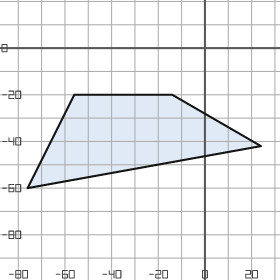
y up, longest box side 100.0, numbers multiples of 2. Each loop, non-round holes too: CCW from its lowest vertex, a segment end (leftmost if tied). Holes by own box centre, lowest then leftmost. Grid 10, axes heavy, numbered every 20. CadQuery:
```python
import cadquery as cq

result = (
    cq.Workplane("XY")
    .moveTo(-76.0, -60.0)
    .lineTo(24.0, -42.0)
    .lineTo(-14.0, -20.0)
    .lineTo(-56.0, -20.0)
    .close()
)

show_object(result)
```